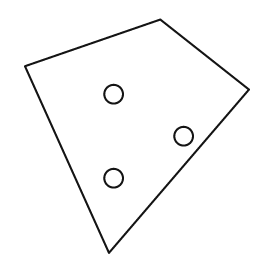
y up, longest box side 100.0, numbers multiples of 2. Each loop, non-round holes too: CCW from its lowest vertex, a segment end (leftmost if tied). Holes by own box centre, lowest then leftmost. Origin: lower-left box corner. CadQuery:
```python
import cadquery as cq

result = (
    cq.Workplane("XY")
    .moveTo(36.0, 0.0)
    .lineTo(96.0, 70.0)
    .lineTo(58.0, 100.0)
    .lineTo(0.0, 80.0)
    .close()
    .moveTo(38.0, 32.0)
    .circle(4.0)
    .moveTo(68.0, 50.0)
    .circle(4.0)
    .moveTo(38.0, 68.0)
    .circle(4.0)
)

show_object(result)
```